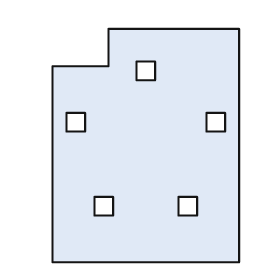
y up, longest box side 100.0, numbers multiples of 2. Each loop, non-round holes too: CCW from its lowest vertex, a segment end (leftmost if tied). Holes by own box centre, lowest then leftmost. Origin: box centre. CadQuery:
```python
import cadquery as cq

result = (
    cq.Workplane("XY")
    .moveTo(-40.0, -50.0)
    .lineTo(40.0, -50.0)
    .lineTo(40.0, 50.0)
    .lineTo(-16.0, 50.0)
    .lineTo(-16.0, 34.0)
    .lineTo(-40.0, 34.0)
    .close()
    .moveTo(-22.0, -30.0)
    .lineTo(-14.0, -30.0)
    .lineTo(-14.0, -22.0)
    .lineTo(-22.0, -22.0)
    .close()
    .moveTo(14.0, -30.0)
    .lineTo(22.0, -30.0)
    .lineTo(22.0, -22.0)
    .lineTo(14.0, -22.0)
    .close()
    .moveTo(-34.0, 6.0)
    .lineTo(-26.0, 6.0)
    .lineTo(-26.0, 14.0)
    .lineTo(-34.0, 14.0)
    .close()
    .moveTo(26.0, 6.0)
    .lineTo(34.0, 6.0)
    .lineTo(34.0, 14.0)
    .lineTo(26.0, 14.0)
    .close()
    .moveTo(-4.0, 28.0)
    .lineTo(4.0, 28.0)
    .lineTo(4.0, 36.0)
    .lineTo(-4.0, 36.0)
    .close()
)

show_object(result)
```